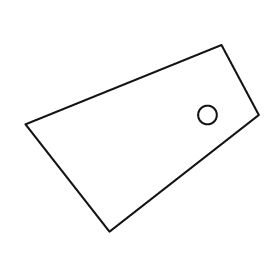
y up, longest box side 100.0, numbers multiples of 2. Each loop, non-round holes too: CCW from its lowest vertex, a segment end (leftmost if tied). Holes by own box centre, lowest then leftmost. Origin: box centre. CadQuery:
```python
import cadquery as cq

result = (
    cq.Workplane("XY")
    .moveTo(-14.0, -40.0)
    .lineTo(50.0, 10.0)
    .lineTo(34.0, 40.0)
    .lineTo(-50.0, 6.0)
    .close()
    .moveTo(28.0, 10.0)
    .circle(4.0)
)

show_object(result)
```